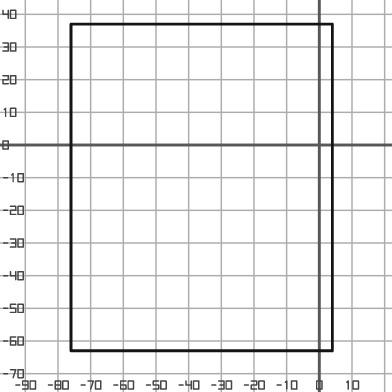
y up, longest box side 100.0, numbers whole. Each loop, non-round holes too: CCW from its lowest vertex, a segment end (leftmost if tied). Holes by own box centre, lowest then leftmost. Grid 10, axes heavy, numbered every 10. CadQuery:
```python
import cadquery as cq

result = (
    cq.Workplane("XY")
    .moveTo(-76.0, -63.0)
    .lineTo(4.0, -63.0)
    .lineTo(4.0, 37.0)
    .lineTo(-76.0, 37.0)
    .close()
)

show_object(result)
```